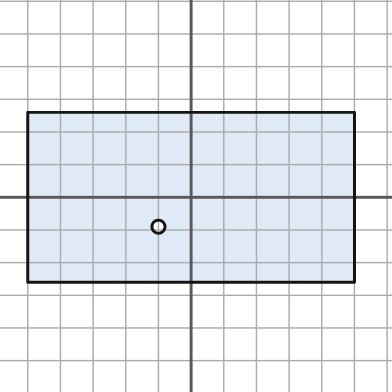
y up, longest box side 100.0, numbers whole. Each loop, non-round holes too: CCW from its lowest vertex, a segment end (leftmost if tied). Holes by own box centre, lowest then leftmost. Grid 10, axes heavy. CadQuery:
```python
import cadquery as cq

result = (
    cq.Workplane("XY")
    .moveTo(-50.0, -26.0)
    .lineTo(50.0, -26.0)
    .lineTo(50.0, 26.0)
    .lineTo(-50.0, 26.0)
    .close()
    .moveTo(-10.0, -9.0)
    .circle(2.0)
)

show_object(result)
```